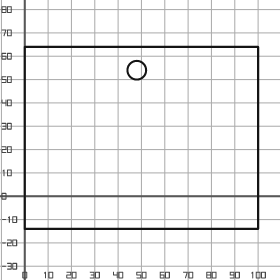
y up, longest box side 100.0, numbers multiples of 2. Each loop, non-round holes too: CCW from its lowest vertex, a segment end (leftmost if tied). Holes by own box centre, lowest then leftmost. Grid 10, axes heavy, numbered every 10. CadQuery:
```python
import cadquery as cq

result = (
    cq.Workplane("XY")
    .moveTo(0.0, -14.0)
    .lineTo(100.0, -14.0)
    .lineTo(100.0, 64.0)
    .lineTo(0.0, 64.0)
    .close()
    .moveTo(48.0, 54.0)
    .circle(4.0)
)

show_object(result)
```